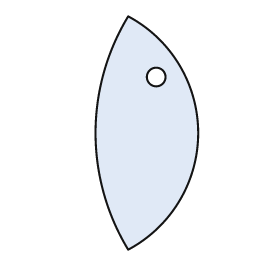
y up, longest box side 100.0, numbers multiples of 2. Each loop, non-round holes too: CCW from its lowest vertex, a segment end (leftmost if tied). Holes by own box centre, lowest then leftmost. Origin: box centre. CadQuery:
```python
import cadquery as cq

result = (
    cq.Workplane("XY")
    .moveTo(-8.0, -50.0)
    .threePointArc((22.0, 0.0), (-8.0, 50.0))
    .threePointArc((-22.0, 0.0), (-8.0, -50.0))
    .close()
    .moveTo(4.0, 24.0)
    .circle(4.0)
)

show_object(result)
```